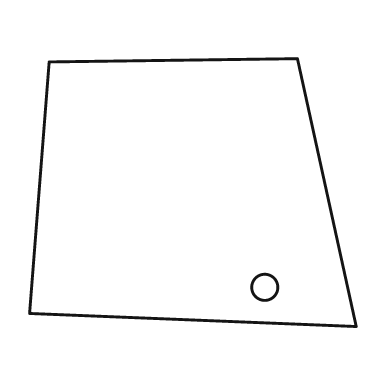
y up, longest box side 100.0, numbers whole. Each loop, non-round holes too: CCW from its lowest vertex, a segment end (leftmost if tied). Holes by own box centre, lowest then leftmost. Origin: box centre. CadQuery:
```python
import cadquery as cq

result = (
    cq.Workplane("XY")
    .moveTo(50.0, -41.0)
    .lineTo(32.0, 41.0)
    .lineTo(-44.0, 40.0)
    .lineTo(-50.0, -37.0)
    .close()
    .moveTo(22.0, -29.0)
    .circle(4.0)
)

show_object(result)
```